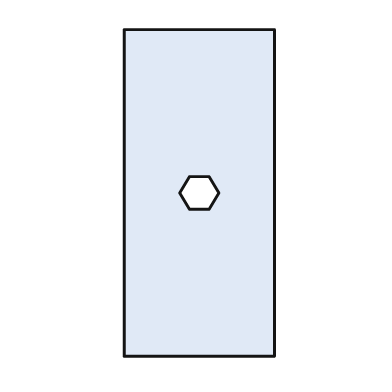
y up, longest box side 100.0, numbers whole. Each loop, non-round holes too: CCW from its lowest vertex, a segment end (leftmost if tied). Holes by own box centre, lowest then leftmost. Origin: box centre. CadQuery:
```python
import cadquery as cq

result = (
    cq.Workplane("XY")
    .moveTo(-23.0, -50.0)
    .lineTo(23.0, -50.0)
    .lineTo(23.0, 50.0)
    .lineTo(-23.0, 50.0)
    .close()
    .moveTo(-3.0, -5.0)
    .lineTo(3.0, -5.0)
    .lineTo(6.0, 0.0)
    .lineTo(3.0, 5.0)
    .lineTo(-3.0, 5.0)
    .lineTo(-6.0, 0.0)
    .close()
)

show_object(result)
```